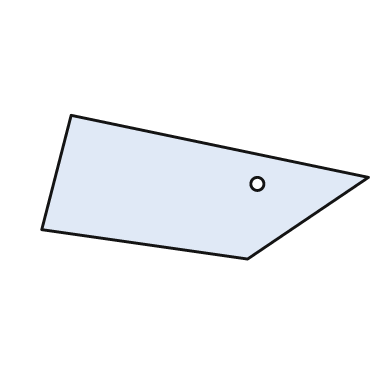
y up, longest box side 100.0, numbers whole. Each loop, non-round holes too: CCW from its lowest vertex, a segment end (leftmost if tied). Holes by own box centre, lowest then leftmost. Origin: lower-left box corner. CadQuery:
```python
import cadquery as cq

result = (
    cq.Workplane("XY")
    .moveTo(63.0, 0.0)
    .lineTo(100.0, 25.0)
    .lineTo(9.0, 44.0)
    .lineTo(0.0, 9.0)
    .close()
    .moveTo(66.0, 23.0)
    .circle(2.0)
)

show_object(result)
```